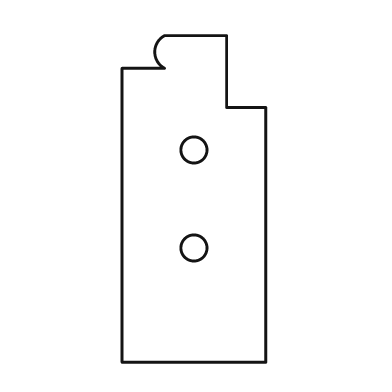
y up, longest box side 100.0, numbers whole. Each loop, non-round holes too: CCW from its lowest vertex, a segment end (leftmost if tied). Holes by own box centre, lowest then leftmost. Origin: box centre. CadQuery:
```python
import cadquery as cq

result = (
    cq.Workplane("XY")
    .moveTo(-22.0, -50.0)
    .lineTo(22.0, -50.0)
    .lineTo(22.0, 28.0)
    .lineTo(10.0, 28.0)
    .lineTo(10.0, 50.0)
    .lineTo(-9.0, 50.0)
    .threePointArc((-12.0, 45.0), (-9.0, 40.0))
    .lineTo(-22.0, 40.0)
    .close()
    .moveTo(0.0, -15.0)
    .circle(4.0)
    .moveTo(0.0, 15.0)
    .circle(4.0)
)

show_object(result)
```